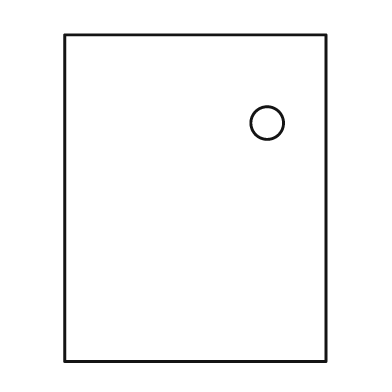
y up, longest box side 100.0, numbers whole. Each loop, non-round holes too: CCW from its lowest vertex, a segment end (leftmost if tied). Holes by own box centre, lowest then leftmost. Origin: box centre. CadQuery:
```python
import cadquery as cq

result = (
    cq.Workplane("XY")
    .moveTo(-40.0, -50.0)
    .lineTo(40.0, -50.0)
    .lineTo(40.0, 50.0)
    .lineTo(-40.0, 50.0)
    .close()
    .moveTo(22.0, 23.0)
    .circle(5.0)
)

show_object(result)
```